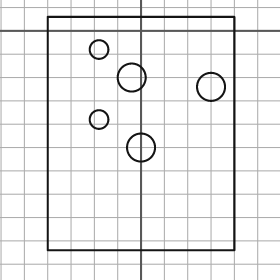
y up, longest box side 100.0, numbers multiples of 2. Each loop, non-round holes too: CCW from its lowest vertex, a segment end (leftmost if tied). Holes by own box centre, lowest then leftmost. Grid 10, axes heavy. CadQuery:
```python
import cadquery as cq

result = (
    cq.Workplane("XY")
    .moveTo(-40.0, -94.0)
    .lineTo(40.0, -94.0)
    .lineTo(40.0, 6.0)
    .lineTo(-40.0, 6.0)
    .close()
    .moveTo(0.0, -50.0)
    .circle(6.0)
    .moveTo(-18.0, -38.0)
    .circle(4.0)
    .moveTo(30.0, -24.0)
    .circle(6.0)
    .moveTo(-4.0, -20.0)
    .circle(6.0)
    .moveTo(-18.0, -8.0)
    .circle(4.0)
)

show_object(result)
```